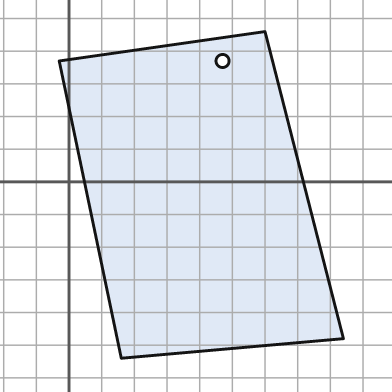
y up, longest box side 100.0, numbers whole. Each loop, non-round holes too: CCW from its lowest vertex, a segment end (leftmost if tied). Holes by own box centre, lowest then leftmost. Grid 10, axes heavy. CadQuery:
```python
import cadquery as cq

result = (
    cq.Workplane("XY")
    .moveTo(16.0, -54.0)
    .lineTo(84.0, -48.0)
    .lineTo(60.0, 46.0)
    .lineTo(-3.0, 37.0)
    .close()
    .moveTo(47.0, 37.0)
    .circle(2.0)
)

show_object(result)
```